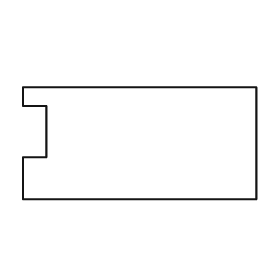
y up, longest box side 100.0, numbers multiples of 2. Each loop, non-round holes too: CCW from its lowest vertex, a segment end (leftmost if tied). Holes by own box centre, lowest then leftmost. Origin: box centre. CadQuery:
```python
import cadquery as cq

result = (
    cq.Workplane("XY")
    .moveTo(-50.0, -24.0)
    .lineTo(50.0, -24.0)
    .lineTo(50.0, 24.0)
    .lineTo(-50.0, 24.0)
    .lineTo(-50.0, 16.0)
    .lineTo(-40.0, 16.0)
    .lineTo(-40.0, -6.0)
    .lineTo(-50.0, -6.0)
    .close()
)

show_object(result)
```